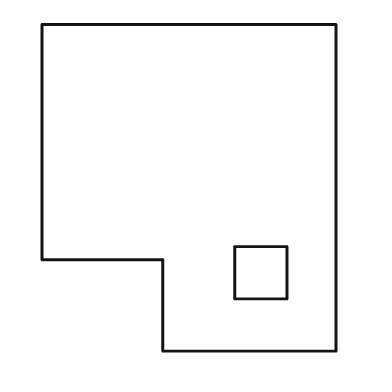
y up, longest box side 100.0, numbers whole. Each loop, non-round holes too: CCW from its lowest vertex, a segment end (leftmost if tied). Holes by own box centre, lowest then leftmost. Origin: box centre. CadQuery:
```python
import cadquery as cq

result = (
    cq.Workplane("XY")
    .moveTo(-8.0, -50.0)
    .lineTo(45.0, -50.0)
    .lineTo(45.0, 50.0)
    .lineTo(-45.0, 50.0)
    .lineTo(-45.0, -22.0)
    .lineTo(-8.0, -22.0)
    .close()
    .moveTo(14.0, -34.0)
    .lineTo(30.0, -34.0)
    .lineTo(30.0, -18.0)
    .lineTo(14.0, -18.0)
    .close()
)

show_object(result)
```